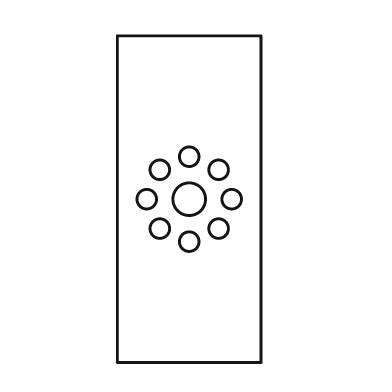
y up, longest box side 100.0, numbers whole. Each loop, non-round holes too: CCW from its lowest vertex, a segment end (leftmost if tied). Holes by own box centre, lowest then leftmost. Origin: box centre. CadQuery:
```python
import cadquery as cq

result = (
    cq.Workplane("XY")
    .moveTo(-22.0, -50.0)
    .lineTo(22.0, -50.0)
    .lineTo(22.0, 50.0)
    .lineTo(-22.0, 50.0)
    .close()
    .moveTo(0.0, -13.0)
    .circle(3.0)
    .moveTo(-9.0, -9.0)
    .circle(3.0)
    .moveTo(9.0, -9.0)
    .circle(3.0)
    .moveTo(-13.0, 0.0)
    .circle(3.0)
    .moveTo(0.0, 0.0)
    .circle(5.0)
    .moveTo(13.0, 0.0)
    .circle(3.0)
    .moveTo(-9.0, 9.0)
    .circle(3.0)
    .moveTo(9.0, 9.0)
    .circle(3.0)
    .moveTo(0.0, 13.0)
    .circle(3.0)
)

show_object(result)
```